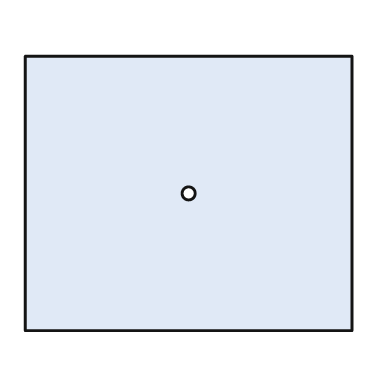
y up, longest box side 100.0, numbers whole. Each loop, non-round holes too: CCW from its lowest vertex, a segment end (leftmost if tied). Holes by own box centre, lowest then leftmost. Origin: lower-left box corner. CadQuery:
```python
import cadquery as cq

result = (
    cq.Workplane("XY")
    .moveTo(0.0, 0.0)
    .lineTo(100.0, 0.0)
    .lineTo(100.0, 84.0)
    .lineTo(0.0, 84.0)
    .close()
    .moveTo(50.0, 42.0)
    .circle(2.0)
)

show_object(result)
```